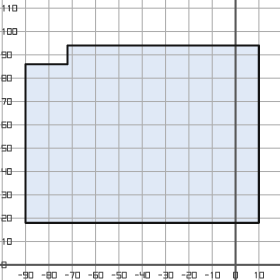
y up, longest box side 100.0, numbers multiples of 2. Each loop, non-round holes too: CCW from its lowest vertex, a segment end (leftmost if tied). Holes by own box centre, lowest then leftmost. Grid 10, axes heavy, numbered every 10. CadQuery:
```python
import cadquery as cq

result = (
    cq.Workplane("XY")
    .moveTo(-90.0, 18.0)
    .lineTo(10.0, 18.0)
    .lineTo(10.0, 94.0)
    .lineTo(-72.0, 94.0)
    .lineTo(-72.0, 86.0)
    .lineTo(-90.0, 86.0)
    .close()
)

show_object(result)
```